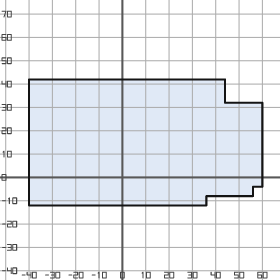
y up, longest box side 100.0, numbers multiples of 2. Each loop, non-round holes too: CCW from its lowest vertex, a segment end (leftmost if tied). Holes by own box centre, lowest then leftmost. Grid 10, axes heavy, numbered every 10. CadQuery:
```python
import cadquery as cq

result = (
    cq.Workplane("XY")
    .moveTo(-40.0, -12.0)
    .lineTo(36.0, -12.0)
    .lineTo(36.0, -8.0)
    .lineTo(56.0, -8.0)
    .lineTo(56.0, -4.0)
    .lineTo(60.0, -4.0)
    .lineTo(60.0, 32.0)
    .lineTo(44.0, 32.0)
    .lineTo(44.0, 42.0)
    .lineTo(-40.0, 42.0)
    .close()
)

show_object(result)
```